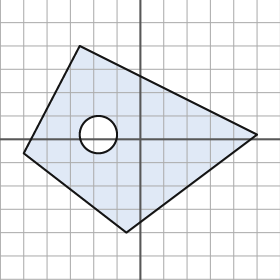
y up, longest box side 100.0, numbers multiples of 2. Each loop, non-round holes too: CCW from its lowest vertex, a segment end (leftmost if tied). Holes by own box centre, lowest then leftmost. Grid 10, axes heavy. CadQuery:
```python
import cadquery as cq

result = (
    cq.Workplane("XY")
    .moveTo(-6.0, -40.0)
    .lineTo(50.0, 2.0)
    .lineTo(-26.0, 40.0)
    .lineTo(-50.0, -6.0)
    .close()
    .moveTo(-18.0, 2.0)
    .circle(8.0)
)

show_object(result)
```